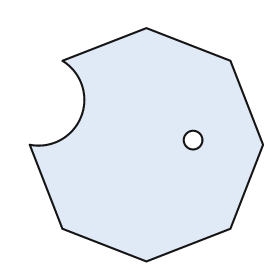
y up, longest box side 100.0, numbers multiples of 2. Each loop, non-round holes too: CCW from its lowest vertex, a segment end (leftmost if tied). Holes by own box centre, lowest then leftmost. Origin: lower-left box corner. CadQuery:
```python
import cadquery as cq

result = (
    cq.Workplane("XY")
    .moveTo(50.0, 0.0)
    .lineTo(86.0, 14.0)
    .lineTo(100.0, 50.0)
    .lineTo(86.0, 86.0)
    .lineTo(50.0, 100.0)
    .lineTo(14.0, 86.0)
    .threePointArc((22.0, 62.0), (0.0, 50.0))
    .lineTo(14.0, 14.0)
    .close()
    .moveTo(70.0, 52.0)
    .circle(4.0)
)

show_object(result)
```